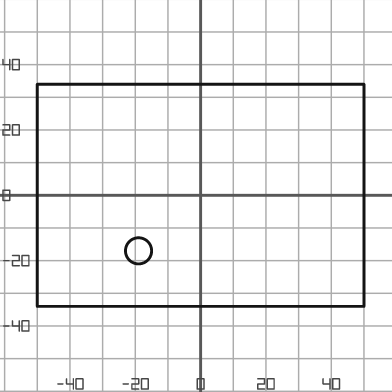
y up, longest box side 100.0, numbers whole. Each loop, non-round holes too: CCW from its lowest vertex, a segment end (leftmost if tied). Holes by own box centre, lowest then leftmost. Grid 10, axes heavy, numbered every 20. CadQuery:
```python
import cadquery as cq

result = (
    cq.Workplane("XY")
    .moveTo(-50.0, -34.0)
    .lineTo(50.0, -34.0)
    .lineTo(50.0, 34.0)
    .lineTo(-50.0, 34.0)
    .close()
    .moveTo(-19.0, -17.0)
    .circle(4.0)
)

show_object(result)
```